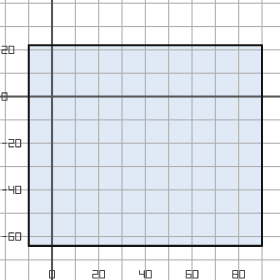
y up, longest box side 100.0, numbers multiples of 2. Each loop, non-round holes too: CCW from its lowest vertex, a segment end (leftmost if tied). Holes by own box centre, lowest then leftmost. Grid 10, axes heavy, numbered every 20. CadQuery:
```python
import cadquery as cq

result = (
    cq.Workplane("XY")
    .moveTo(-10.0, -64.0)
    .lineTo(90.0, -64.0)
    .lineTo(90.0, 22.0)
    .lineTo(-10.0, 22.0)
    .close()
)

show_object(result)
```